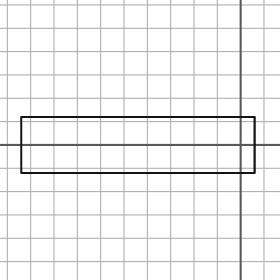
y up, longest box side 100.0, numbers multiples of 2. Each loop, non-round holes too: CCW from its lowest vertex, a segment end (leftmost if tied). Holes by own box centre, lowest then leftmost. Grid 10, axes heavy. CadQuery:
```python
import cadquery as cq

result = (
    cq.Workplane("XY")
    .moveTo(-94.0, -12.0)
    .lineTo(6.0, -12.0)
    .lineTo(6.0, 12.0)
    .lineTo(-94.0, 12.0)
    .close()
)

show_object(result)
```